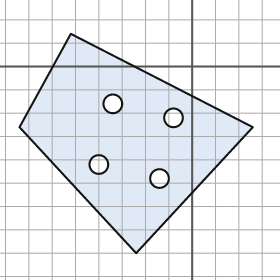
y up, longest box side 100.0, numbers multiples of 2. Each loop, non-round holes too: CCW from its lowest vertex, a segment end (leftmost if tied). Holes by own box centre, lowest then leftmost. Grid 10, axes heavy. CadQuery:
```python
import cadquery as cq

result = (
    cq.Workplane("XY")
    .moveTo(-24.0, -80.0)
    .lineTo(26.0, -26.0)
    .lineTo(-52.0, 14.0)
    .lineTo(-74.0, -26.0)
    .close()
    .moveTo(-14.0, -48.0)
    .circle(4.0)
    .moveTo(-40.0, -42.0)
    .circle(4.0)
    .moveTo(-8.0, -22.0)
    .circle(4.0)
    .moveTo(-34.0, -16.0)
    .circle(4.0)
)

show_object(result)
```